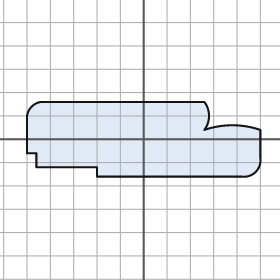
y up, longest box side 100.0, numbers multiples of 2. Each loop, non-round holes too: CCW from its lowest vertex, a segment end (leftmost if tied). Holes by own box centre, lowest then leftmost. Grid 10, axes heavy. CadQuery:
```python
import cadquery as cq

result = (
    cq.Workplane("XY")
    .moveTo(-20.0, -16.0)
    .lineTo(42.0, -16.0)
    .threePointArc((48.0, -14.0), (50.0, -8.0))
    .lineTo(50.0, 4.0)
    .threePointArc((38.0, 6.0), (26.0, 4.0))
    .threePointArc((28.0, 10.0), (26.0, 16.0))
    .lineTo(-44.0, 16.0)
    .threePointArc((-48.0, 14.0), (-50.0, 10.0))
    .lineTo(-50.0, -6.0)
    .lineTo(-46.0, -6.0)
    .lineTo(-46.0, -12.0)
    .lineTo(-20.0, -12.0)
    .close()
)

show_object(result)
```